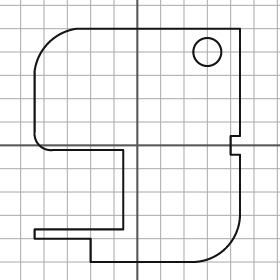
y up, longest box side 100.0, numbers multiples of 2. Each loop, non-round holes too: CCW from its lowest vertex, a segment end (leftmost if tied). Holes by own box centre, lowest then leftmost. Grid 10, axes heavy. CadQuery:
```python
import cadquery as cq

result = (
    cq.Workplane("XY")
    .moveTo(-20.0, -50.0)
    .lineTo(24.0, -50.0)
    .threePointArc((38.0, -44.0), (44.0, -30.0))
    .lineTo(44.0, -4.0)
    .lineTo(40.0, -4.0)
    .lineTo(40.0, 4.0)
    .lineTo(44.0, 4.0)
    .lineTo(44.0, 50.0)
    .lineTo(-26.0, 50.0)
    .threePointArc((-38.0, 44.0), (-44.0, 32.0))
    .lineTo(-44.0, 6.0)
    .threePointArc((-42.0, 0.0), (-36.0, -2.0))
    .lineTo(-6.0, -2.0)
    .lineTo(-6.0, -36.0)
    .lineTo(-44.0, -36.0)
    .lineTo(-44.0, -40.0)
    .lineTo(-20.0, -40.0)
    .close()
    .moveTo(30.0, 40.0)
    .circle(6.0)
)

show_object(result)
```